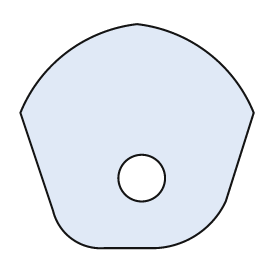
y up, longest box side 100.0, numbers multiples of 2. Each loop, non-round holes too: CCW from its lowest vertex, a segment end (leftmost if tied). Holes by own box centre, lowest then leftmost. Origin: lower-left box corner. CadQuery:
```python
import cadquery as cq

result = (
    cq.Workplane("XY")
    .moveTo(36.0, 0.0)
    .lineTo(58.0, 0.0)
    .threePointArc((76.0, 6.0), (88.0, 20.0))
    .lineTo(100.0, 58.0)
    .threePointArc((80.0, 84.0), (50.0, 96.0))
    .threePointArc((20.0, 84.0), (0.0, 58.0))
    .lineTo(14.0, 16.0)
    .threePointArc((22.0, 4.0), (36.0, 0.0))
    .close()
    .moveTo(52.0, 30.0)
    .circle(10.0)
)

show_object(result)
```